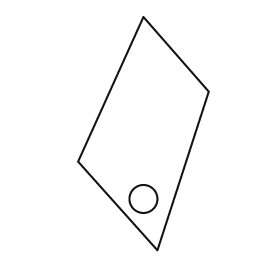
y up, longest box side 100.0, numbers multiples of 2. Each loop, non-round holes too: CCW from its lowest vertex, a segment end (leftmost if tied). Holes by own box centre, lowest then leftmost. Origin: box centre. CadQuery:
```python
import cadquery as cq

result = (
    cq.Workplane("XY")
    .moveTo(6.0, -50.0)
    .lineTo(28.0, 18.0)
    .lineTo(0.0, 50.0)
    .lineTo(-28.0, -12.0)
    .close()
    .moveTo(0.0, -28.0)
    .circle(6.0)
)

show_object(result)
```